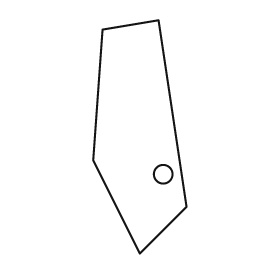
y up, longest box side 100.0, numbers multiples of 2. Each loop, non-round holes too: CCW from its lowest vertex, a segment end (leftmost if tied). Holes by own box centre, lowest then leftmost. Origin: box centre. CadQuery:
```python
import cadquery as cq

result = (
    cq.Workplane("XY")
    .moveTo(0.0, -50.0)
    .lineTo(20.0, -30.0)
    .lineTo(8.0, 50.0)
    .lineTo(-16.0, 46.0)
    .lineTo(-20.0, -10.0)
    .close()
    .moveTo(10.0, -16.0)
    .circle(4.0)
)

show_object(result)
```